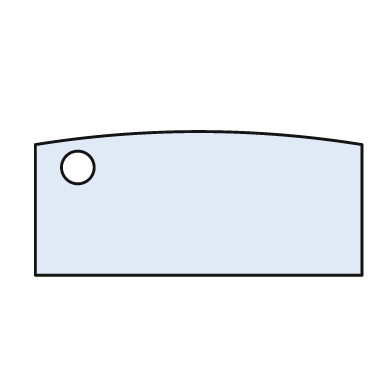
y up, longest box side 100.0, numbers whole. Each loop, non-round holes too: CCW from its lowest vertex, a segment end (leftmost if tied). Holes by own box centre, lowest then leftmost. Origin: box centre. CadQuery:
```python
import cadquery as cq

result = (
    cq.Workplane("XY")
    .moveTo(-50.0, -22.0)
    .lineTo(50.0, -22.0)
    .lineTo(50.0, 18.0)
    .threePointArc((0.0, 22.0), (-50.0, 18.0))
    .close()
    .moveTo(-37.0, 11.0)
    .circle(5.0)
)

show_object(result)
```